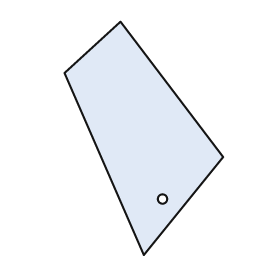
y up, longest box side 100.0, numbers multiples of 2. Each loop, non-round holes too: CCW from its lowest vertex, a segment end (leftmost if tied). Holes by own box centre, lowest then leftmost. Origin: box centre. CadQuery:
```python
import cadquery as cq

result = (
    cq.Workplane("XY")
    .moveTo(0.0, -50.0)
    .lineTo(34.0, -8.0)
    .lineTo(-10.0, 50.0)
    .lineTo(-34.0, 28.0)
    .close()
    .moveTo(8.0, -26.0)
    .circle(2.0)
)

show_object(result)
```